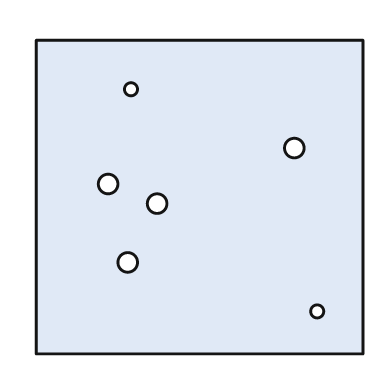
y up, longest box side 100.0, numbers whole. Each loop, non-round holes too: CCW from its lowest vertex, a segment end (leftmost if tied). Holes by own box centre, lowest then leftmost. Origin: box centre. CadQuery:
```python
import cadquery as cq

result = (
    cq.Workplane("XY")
    .moveTo(-50.0, -48.0)
    .lineTo(50.0, -48.0)
    .lineTo(50.0, 48.0)
    .lineTo(-50.0, 48.0)
    .close()
    .moveTo(36.0, -35.0)
    .circle(2.0)
    .moveTo(-22.0, -20.0)
    .circle(3.0)
    .moveTo(-13.0, -2.0)
    .circle(3.0)
    .moveTo(-28.0, 4.0)
    .circle(3.0)
    .moveTo(29.0, 15.0)
    .circle(3.0)
    .moveTo(-21.0, 33.0)
    .circle(2.0)
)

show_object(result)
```